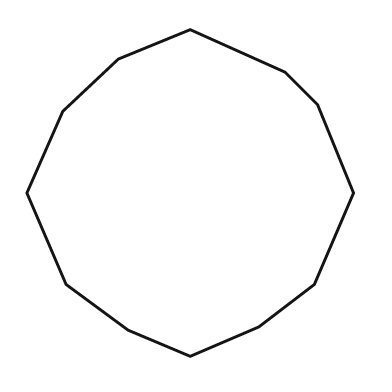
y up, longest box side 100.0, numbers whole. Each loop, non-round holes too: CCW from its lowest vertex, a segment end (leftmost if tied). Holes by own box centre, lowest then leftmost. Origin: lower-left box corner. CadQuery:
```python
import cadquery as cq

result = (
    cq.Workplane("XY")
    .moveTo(50.0, 0.0)
    .lineTo(71.0, 9.0)
    .lineTo(88.0, 22.0)
    .lineTo(100.0, 50.0)
    .lineTo(89.0, 77.0)
    .lineTo(79.0, 87.0)
    .lineTo(50.0, 100.0)
    .lineTo(28.0, 91.0)
    .lineTo(11.0, 75.0)
    .lineTo(0.0, 50.0)
    .lineTo(12.0, 22.0)
    .lineTo(31.0, 8.0)
    .close()
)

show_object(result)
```